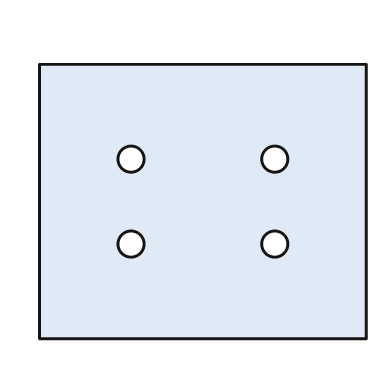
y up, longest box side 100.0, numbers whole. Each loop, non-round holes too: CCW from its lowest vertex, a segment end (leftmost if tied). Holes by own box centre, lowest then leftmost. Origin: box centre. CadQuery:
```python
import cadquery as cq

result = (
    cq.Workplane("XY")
    .moveTo(-50.0, -42.0)
    .lineTo(50.0, -42.0)
    .lineTo(50.0, 42.0)
    .lineTo(-50.0, 42.0)
    .close()
    .moveTo(-22.0, -13.0)
    .circle(4.0)
    .moveTo(22.0, -13.0)
    .circle(4.0)
    .moveTo(-22.0, 13.0)
    .circle(4.0)
    .moveTo(22.0, 13.0)
    .circle(4.0)
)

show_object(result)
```